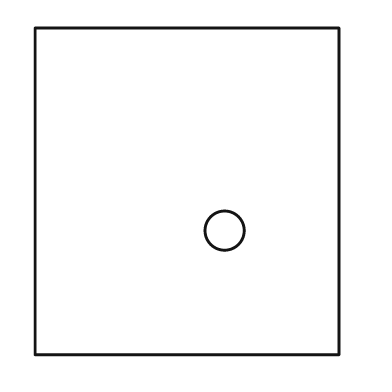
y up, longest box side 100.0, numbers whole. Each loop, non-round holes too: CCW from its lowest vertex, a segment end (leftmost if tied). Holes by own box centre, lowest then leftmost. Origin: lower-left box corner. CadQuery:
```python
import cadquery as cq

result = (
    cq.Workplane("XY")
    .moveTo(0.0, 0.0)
    .lineTo(93.0, 0.0)
    .lineTo(93.0, 100.0)
    .lineTo(0.0, 100.0)
    .close()
    .moveTo(58.0, 38.0)
    .circle(6.0)
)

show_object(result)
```